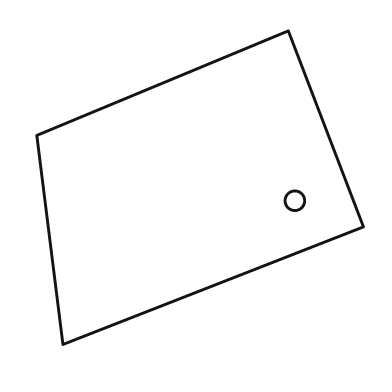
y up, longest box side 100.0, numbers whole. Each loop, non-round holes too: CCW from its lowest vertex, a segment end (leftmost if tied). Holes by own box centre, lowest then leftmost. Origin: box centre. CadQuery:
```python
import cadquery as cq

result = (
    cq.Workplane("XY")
    .moveTo(-42.0, -48.0)
    .lineTo(50.0, -12.0)
    .lineTo(27.0, 48.0)
    .lineTo(-50.0, 16.0)
    .close()
    .moveTo(29.0, -4.0)
    .circle(3.0)
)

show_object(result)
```